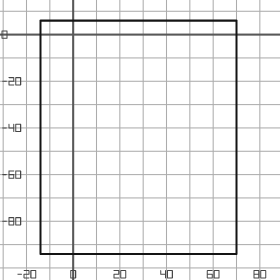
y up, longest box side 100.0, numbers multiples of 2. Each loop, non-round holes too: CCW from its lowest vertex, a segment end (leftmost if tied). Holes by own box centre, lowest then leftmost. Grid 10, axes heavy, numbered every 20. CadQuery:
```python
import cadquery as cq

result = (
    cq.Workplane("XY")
    .moveTo(-14.0, -94.0)
    .lineTo(70.0, -94.0)
    .lineTo(70.0, 6.0)
    .lineTo(-14.0, 6.0)
    .close()
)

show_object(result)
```